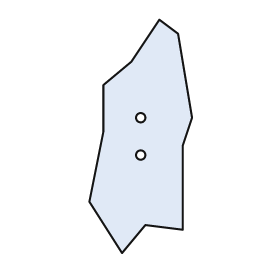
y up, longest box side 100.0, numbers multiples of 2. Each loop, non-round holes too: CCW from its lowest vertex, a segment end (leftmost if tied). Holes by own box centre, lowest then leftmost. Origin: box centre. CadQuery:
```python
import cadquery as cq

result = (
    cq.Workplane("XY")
    .moveTo(-8.0, -50.0)
    .lineTo(2.0, -38.0)
    .lineTo(18.0, -40.0)
    .lineTo(18.0, -4.0)
    .lineTo(22.0, 8.0)
    .lineTo(16.0, 44.0)
    .lineTo(8.0, 50.0)
    .lineTo(-4.0, 32.0)
    .lineTo(-16.0, 22.0)
    .lineTo(-16.0, 2.0)
    .lineTo(-22.0, -28.0)
    .close()
    .moveTo(0.0, -8.0)
    .circle(2.0)
    .moveTo(0.0, 8.0)
    .circle(2.0)
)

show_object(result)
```